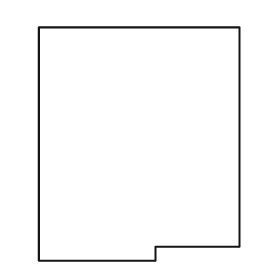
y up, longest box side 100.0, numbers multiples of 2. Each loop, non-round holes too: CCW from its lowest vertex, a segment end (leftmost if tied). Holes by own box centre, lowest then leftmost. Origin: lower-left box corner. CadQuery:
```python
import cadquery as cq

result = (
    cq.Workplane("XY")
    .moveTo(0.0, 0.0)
    .lineTo(50.0, 0.0)
    .lineTo(50.0, 6.0)
    .lineTo(86.0, 6.0)
    .lineTo(86.0, 100.0)
    .lineTo(0.0, 100.0)
    .close()
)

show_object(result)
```